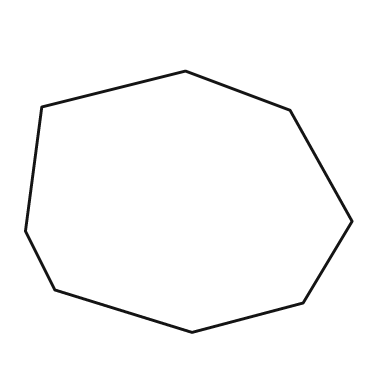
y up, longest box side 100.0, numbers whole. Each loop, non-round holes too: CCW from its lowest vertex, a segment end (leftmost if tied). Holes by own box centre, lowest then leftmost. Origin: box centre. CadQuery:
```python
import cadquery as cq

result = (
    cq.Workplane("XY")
    .moveTo(1.0, -40.0)
    .lineTo(35.0, -31.0)
    .lineTo(50.0, -6.0)
    .lineTo(31.0, 28.0)
    .lineTo(-1.0, 40.0)
    .lineTo(-45.0, 29.0)
    .lineTo(-50.0, -9.0)
    .lineTo(-41.0, -27.0)
    .close()
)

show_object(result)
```